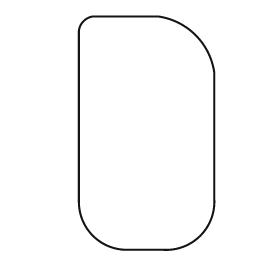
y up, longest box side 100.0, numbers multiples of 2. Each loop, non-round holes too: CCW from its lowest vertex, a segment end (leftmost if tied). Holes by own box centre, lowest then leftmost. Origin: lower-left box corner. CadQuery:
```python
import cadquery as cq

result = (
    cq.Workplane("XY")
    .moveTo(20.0, 0.0)
    .lineTo(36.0, 0.0)
    .threePointArc((52.0, 6.0), (58.0, 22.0))
    .lineTo(58.0, 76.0)
    .threePointArc((50.0, 92.0), (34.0, 100.0))
    .lineTo(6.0, 100.0)
    .threePointArc((2.0, 98.0), (0.0, 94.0))
    .lineTo(0.0, 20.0)
    .threePointArc((6.0, 6.0), (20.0, 0.0))
    .close()
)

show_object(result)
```